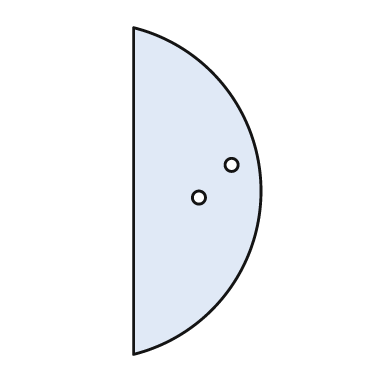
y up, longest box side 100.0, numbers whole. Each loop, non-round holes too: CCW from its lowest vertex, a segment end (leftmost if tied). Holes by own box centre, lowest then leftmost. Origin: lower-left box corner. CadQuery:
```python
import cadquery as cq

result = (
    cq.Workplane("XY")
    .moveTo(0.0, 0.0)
    .threePointArc((39.0, 50.0), (0.0, 100.0))
    .close()
    .moveTo(20.0, 48.0)
    .circle(2.0)
    .moveTo(30.0, 58.0)
    .circle(2.0)
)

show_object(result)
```